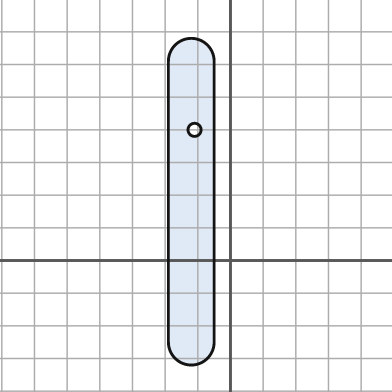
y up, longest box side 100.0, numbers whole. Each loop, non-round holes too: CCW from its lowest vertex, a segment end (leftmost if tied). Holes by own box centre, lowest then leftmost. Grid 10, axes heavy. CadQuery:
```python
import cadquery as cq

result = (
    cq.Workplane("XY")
    .moveTo(-19.0, -25.0)
    .threePointArc((-12.0, -32.0), (-5.0, -25.0))
    .lineTo(-5.0, 61.0)
    .threePointArc((-12.0, 68.0), (-19.0, 61.0))
    .close()
    .moveTo(-11.0, 40.0)
    .circle(2.0)
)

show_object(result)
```